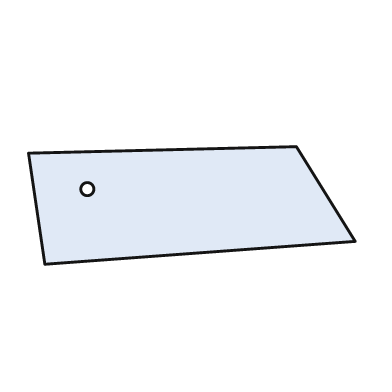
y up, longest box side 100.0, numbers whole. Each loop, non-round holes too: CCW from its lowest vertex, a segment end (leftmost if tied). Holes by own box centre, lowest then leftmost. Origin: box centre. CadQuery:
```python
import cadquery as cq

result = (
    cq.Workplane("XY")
    .moveTo(-45.0, -18.0)
    .lineTo(50.0, -11.0)
    .lineTo(32.0, 18.0)
    .lineTo(-50.0, 16.0)
    .close()
    .moveTo(-32.0, 5.0)
    .circle(2.0)
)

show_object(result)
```